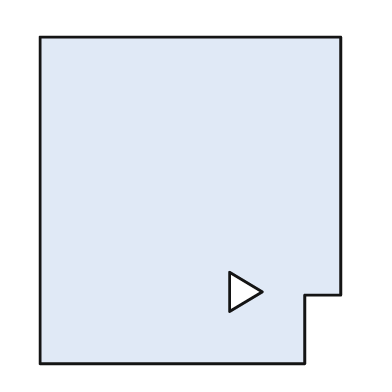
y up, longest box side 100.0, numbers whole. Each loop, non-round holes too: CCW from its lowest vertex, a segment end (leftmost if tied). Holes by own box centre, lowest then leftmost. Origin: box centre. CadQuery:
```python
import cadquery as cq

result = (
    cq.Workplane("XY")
    .moveTo(-46.0, -50.0)
    .lineTo(35.0, -50.0)
    .lineTo(35.0, -29.0)
    .lineTo(46.0, -29.0)
    .lineTo(46.0, 50.0)
    .lineTo(-46.0, 50.0)
    .close()
    .moveTo(12.0, -34.0)
    .lineTo(22.0, -28.0)
    .lineTo(12.0, -22.0)
    .close()
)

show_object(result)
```